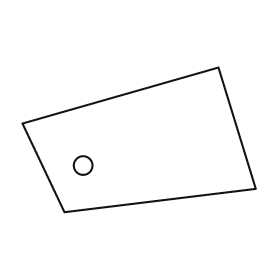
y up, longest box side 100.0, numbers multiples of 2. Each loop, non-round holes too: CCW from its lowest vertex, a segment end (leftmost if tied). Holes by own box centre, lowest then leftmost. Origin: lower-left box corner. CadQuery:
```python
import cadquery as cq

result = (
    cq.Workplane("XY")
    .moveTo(18.0, 0.0)
    .lineTo(100.0, 10.0)
    .lineTo(84.0, 62.0)
    .lineTo(0.0, 38.0)
    .close()
    .moveTo(26.0, 20.0)
    .circle(4.0)
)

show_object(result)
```